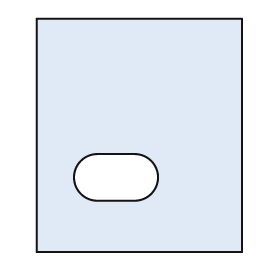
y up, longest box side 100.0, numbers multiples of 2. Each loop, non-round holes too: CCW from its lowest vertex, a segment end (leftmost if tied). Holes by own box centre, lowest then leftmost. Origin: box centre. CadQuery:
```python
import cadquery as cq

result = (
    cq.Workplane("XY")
    .moveTo(-44.0, -50.0)
    .lineTo(44.0, -50.0)
    .lineTo(44.0, 50.0)
    .lineTo(-44.0, 50.0)
    .close()
    .moveTo(-18.0, -28.0)
    .lineTo(-2.0, -28.0)
    .threePointArc((8.0, -18.0), (-2.0, -8.0))
    .lineTo(-18.0, -8.0)
    .threePointArc((-28.0, -18.0), (-18.0, -28.0))
    .close()
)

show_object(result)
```